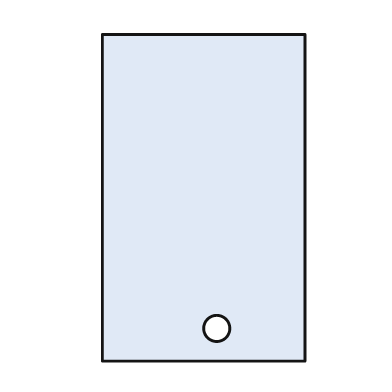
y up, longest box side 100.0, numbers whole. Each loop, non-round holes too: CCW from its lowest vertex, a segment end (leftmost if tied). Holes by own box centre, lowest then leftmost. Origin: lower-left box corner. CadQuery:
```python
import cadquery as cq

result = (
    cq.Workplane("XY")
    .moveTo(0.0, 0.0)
    .lineTo(62.0, 0.0)
    .lineTo(62.0, 100.0)
    .lineTo(0.0, 100.0)
    .close()
    .moveTo(35.0, 10.0)
    .circle(4.0)
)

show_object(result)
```